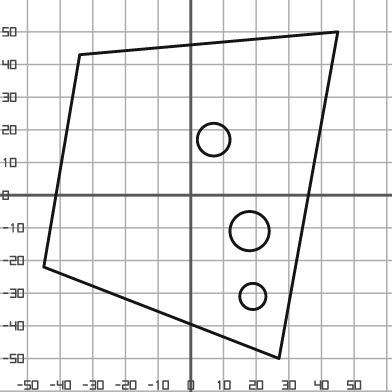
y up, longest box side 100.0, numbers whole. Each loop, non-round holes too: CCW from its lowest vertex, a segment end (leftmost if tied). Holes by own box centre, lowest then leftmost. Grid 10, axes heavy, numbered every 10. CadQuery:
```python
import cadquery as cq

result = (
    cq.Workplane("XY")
    .moveTo(27.0, -50.0)
    .lineTo(45.0, 50.0)
    .lineTo(-34.0, 43.0)
    .lineTo(-45.0, -22.0)
    .close()
    .moveTo(19.0, -31.0)
    .circle(4.0)
    .moveTo(18.0, -11.0)
    .circle(6.0)
    .moveTo(7.0, 17.0)
    .circle(5.0)
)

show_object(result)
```